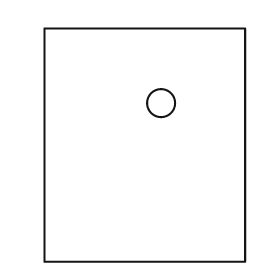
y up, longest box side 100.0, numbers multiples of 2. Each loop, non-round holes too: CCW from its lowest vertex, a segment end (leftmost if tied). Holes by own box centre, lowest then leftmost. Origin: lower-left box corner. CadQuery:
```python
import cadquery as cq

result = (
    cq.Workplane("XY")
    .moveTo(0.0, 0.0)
    .lineTo(86.0, 0.0)
    .lineTo(86.0, 100.0)
    .lineTo(0.0, 100.0)
    .close()
    .moveTo(50.0, 68.0)
    .circle(6.0)
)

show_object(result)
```